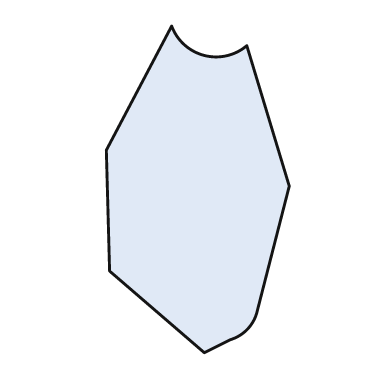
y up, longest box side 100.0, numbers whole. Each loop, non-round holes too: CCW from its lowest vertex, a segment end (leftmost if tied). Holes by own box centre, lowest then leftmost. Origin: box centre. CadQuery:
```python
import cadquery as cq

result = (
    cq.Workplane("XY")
    .moveTo(2.0, -50.0)
    .lineTo(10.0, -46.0)
    .threePointArc((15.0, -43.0), (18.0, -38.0))
    .lineTo(28.0, 1.0)
    .lineTo(15.0, 44.0)
    .threePointArc((2.0, 41.0), (-8.0, 50.0))
    .lineTo(-28.0, 12.0)
    .lineTo(-27.0, -25.0)
    .close()
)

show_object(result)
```